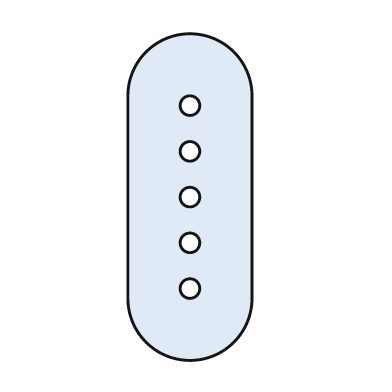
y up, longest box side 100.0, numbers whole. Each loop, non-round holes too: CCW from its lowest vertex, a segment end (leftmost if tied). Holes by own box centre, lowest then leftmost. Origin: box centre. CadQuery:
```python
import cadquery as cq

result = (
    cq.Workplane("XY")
    .moveTo(-19.0, -31.0)
    .threePointArc((0.0, -50.0), (19.0, -31.0))
    .lineTo(19.0, 31.0)
    .threePointArc((0.0, 50.0), (-19.0, 31.0))
    .close()
    .moveTo(0.0, -28.0)
    .circle(3.0)
    .moveTo(0.0, -14.0)
    .circle(3.0)
    .moveTo(0.0, 0.0)
    .circle(3.0)
    .moveTo(0.0, 14.0)
    .circle(3.0)
    .moveTo(0.0, 28.0)
    .circle(3.0)
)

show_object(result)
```